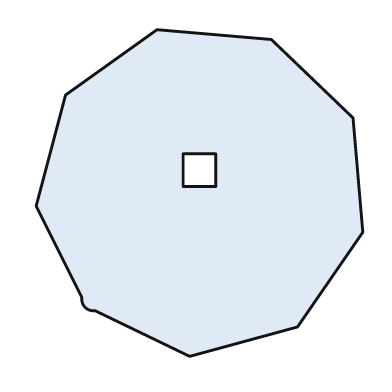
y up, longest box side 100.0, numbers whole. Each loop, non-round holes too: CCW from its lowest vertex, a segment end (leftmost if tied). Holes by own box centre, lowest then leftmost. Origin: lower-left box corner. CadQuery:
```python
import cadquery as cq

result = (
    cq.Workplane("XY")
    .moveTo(47.0, 0.0)
    .lineTo(80.0, 9.0)
    .lineTo(100.0, 38.0)
    .lineTo(97.0, 73.0)
    .lineTo(72.0, 97.0)
    .lineTo(37.0, 100.0)
    .lineTo(9.0, 80.0)
    .lineTo(0.0, 46.0)
    .lineTo(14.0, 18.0)
    .threePointArc((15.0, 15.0), (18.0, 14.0))
    .close()
    .moveTo(45.0, 52.0)
    .lineTo(55.0, 52.0)
    .lineTo(55.0, 62.0)
    .lineTo(45.0, 62.0)
    .close()
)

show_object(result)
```